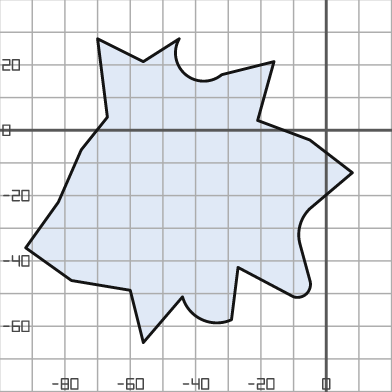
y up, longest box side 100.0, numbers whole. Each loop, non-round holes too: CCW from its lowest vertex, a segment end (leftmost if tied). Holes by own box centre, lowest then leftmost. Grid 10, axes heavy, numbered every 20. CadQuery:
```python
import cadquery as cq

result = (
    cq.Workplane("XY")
    .moveTo(-56.0, -65.0)
    .lineTo(-44.0, -51.0)
    .threePointArc((-38.0, -58.0), (-29.0, -58.0))
    .lineTo(-27.0, -42.0)
    .lineTo(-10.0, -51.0)
    .threePointArc((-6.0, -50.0), (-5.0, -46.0))
    .lineTo(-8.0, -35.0)
    .threePointArc((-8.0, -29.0), (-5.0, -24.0))
    .lineTo(8.0, -13.0)
    .lineTo(-5.0, -3.0)
    .lineTo(-21.0, 3.0)
    .lineTo(-16.0, 21.0)
    .lineTo(-32.0, 17.0)
    .threePointArc((-43.0, 17.0), (-45.0, 28.0))
    .lineTo(-56.0, 21.0)
    .lineTo(-70.0, 28.0)
    .lineTo(-67.0, 4.0)
    .lineTo(-75.0, -6.0)
    .lineTo(-82.0, -22.0)
    .lineTo(-92.0, -36.0)
    .lineTo(-78.0, -46.0)
    .lineTo(-60.0, -49.0)
    .close()
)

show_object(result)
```